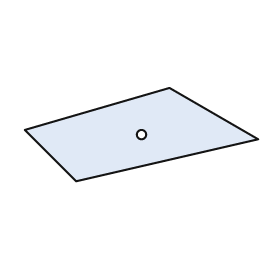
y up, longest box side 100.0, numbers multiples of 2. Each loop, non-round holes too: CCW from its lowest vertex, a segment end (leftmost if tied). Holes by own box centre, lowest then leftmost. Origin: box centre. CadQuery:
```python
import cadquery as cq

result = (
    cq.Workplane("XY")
    .moveTo(-28.0, -20.0)
    .lineTo(50.0, -2.0)
    .lineTo(12.0, 20.0)
    .lineTo(-50.0, 2.0)
    .close()
    .moveTo(0.0, 0.0)
    .circle(2.0)
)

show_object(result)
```